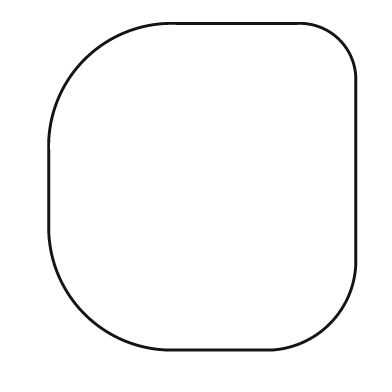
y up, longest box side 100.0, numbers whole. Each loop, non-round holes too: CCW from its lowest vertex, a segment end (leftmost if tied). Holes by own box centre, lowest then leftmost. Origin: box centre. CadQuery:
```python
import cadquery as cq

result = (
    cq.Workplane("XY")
    .moveTo(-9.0, -50.0)
    .lineTo(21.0, -50.0)
    .threePointArc((39.0, -42.0), (47.0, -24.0))
    .lineTo(47.0, 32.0)
    .threePointArc((42.0, 45.0), (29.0, 50.0))
    .lineTo(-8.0, 50.0)
    .threePointArc((-36.0, 39.0), (-47.0, 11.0))
    .lineTo(-47.0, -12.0)
    .threePointArc((-36.0, -39.0), (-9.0, -50.0))
    .close()
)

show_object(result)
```